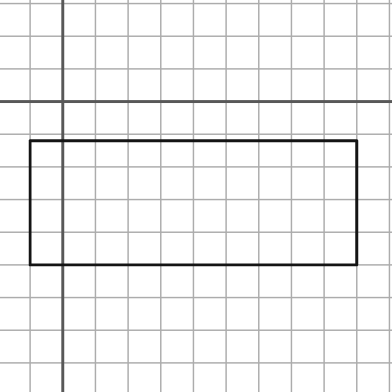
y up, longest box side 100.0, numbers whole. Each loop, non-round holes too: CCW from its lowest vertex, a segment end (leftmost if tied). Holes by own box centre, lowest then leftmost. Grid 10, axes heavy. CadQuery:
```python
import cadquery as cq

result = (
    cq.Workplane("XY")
    .moveTo(-10.0, -50.0)
    .lineTo(90.0, -50.0)
    .lineTo(90.0, -12.0)
    .lineTo(-10.0, -12.0)
    .close()
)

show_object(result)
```